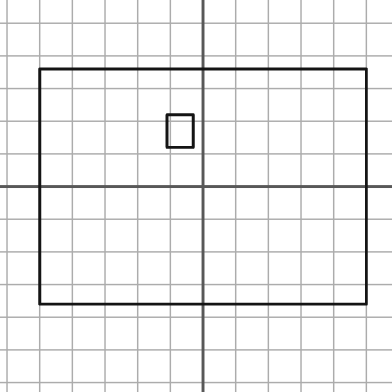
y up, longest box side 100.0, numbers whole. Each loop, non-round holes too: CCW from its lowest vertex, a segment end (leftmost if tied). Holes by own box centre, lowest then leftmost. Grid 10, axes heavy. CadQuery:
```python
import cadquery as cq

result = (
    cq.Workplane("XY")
    .moveTo(-50.0, -36.0)
    .lineTo(50.0, -36.0)
    .lineTo(50.0, 36.0)
    .lineTo(-50.0, 36.0)
    .close()
    .moveTo(-11.0, 12.0)
    .lineTo(-3.0, 12.0)
    .lineTo(-3.0, 22.0)
    .lineTo(-11.0, 22.0)
    .close()
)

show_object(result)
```